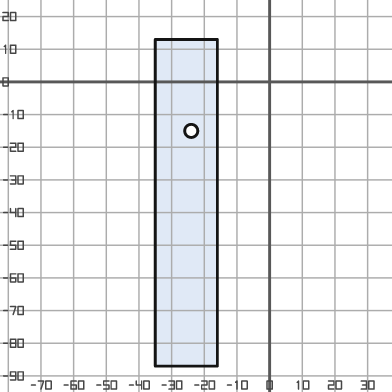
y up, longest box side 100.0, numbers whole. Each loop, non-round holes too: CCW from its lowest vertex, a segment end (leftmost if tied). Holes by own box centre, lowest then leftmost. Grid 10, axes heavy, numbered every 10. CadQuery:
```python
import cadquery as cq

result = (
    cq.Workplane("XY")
    .moveTo(-35.0, -87.0)
    .lineTo(-16.0, -87.0)
    .lineTo(-16.0, 13.0)
    .lineTo(-35.0, 13.0)
    .close()
    .moveTo(-24.0, -15.0)
    .circle(2.0)
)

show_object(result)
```